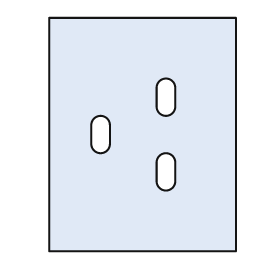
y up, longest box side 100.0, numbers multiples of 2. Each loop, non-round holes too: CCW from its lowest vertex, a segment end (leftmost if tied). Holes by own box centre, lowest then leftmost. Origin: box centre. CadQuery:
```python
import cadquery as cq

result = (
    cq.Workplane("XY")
    .moveTo(-40.0, -50.0)
    .lineTo(40.0, -50.0)
    .lineTo(40.0, 50.0)
    .lineTo(-40.0, 50.0)
    .close()
    .moveTo(6.0, -20.0)
    .threePointArc((10.0, -24.0), (14.0, -20.0))
    .lineTo(14.0, -12.0)
    .threePointArc((10.0, -8.0), (6.0, -12.0))
    .close()
    .moveTo(-22.0, -4.0)
    .threePointArc((-18.0, -8.0), (-14.0, -4.0))
    .lineTo(-14.0, 4.0)
    .threePointArc((-18.0, 8.0), (-22.0, 4.0))
    .close()
    .moveTo(6.0, 12.0)
    .threePointArc((10.0, 8.0), (14.0, 12.0))
    .lineTo(14.0, 20.0)
    .threePointArc((10.0, 24.0), (6.0, 20.0))
    .close()
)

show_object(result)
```